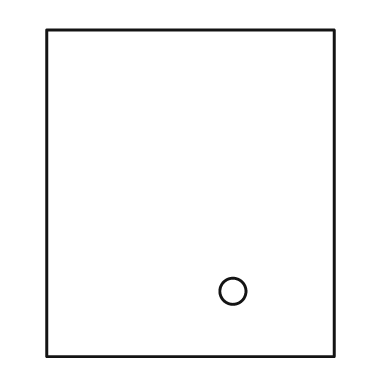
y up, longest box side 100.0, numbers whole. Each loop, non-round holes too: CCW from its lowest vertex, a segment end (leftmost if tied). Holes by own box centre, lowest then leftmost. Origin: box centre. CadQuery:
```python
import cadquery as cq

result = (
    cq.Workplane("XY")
    .moveTo(-44.0, -50.0)
    .lineTo(44.0, -50.0)
    .lineTo(44.0, 50.0)
    .lineTo(-44.0, 50.0)
    .close()
    .moveTo(13.0, -30.0)
    .circle(4.0)
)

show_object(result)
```